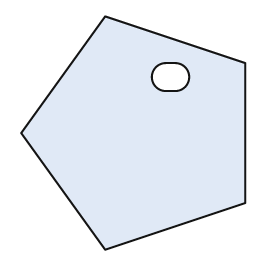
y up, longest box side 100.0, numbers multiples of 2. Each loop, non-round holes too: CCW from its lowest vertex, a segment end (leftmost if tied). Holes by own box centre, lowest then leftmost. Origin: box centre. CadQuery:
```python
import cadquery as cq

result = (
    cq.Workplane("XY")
    .moveTo(-12.0, -50.0)
    .lineTo(48.0, -30.0)
    .lineTo(48.0, 30.0)
    .lineTo(-12.0, 50.0)
    .lineTo(-48.0, 0.0)
    .close()
    .moveTo(14.0, 18.0)
    .lineTo(18.0, 18.0)
    .threePointArc((24.0, 24.0), (18.0, 30.0))
    .lineTo(14.0, 30.0)
    .threePointArc((8.0, 24.0), (14.0, 18.0))
    .close()
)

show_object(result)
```